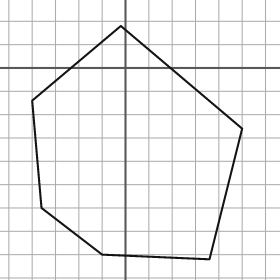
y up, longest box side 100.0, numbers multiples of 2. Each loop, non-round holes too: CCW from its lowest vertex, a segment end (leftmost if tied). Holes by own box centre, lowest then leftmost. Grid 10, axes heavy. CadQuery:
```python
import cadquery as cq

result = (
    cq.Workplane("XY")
    .moveTo(36.0, -82.0)
    .lineTo(50.0, -26.0)
    .lineTo(-2.0, 18.0)
    .lineTo(-40.0, -14.0)
    .lineTo(-36.0, -60.0)
    .lineTo(-10.0, -80.0)
    .close()
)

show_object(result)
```